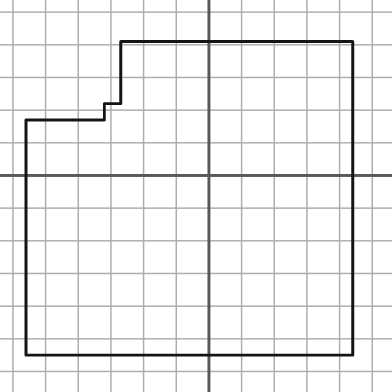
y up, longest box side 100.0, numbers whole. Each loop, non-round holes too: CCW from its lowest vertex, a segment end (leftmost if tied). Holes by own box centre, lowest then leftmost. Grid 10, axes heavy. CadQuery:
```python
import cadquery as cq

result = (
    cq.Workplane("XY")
    .moveTo(-56.0, -55.0)
    .lineTo(44.0, -55.0)
    .lineTo(44.0, 41.0)
    .lineTo(-27.0, 41.0)
    .lineTo(-27.0, 22.0)
    .lineTo(-32.0, 22.0)
    .lineTo(-32.0, 17.0)
    .lineTo(-56.0, 17.0)
    .close()
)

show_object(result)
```